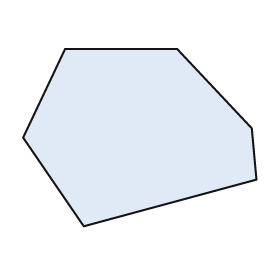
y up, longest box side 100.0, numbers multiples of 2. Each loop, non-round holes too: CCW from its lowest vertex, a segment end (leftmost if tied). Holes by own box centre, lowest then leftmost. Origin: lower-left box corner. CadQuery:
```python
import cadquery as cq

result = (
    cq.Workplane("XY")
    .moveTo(26.0, 0.0)
    .lineTo(100.0, 20.0)
    .lineTo(98.0, 42.0)
    .lineTo(66.0, 76.0)
    .lineTo(18.0, 76.0)
    .lineTo(0.0, 38.0)
    .close()
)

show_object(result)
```